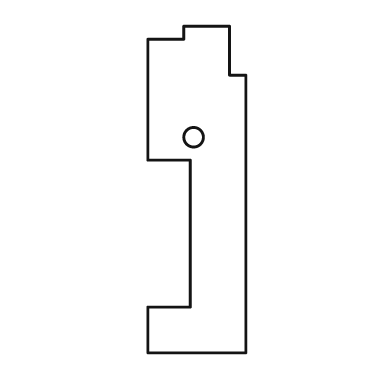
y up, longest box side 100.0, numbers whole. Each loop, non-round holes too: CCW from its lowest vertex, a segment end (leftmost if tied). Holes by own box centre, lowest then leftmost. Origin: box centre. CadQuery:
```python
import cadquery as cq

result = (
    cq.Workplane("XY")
    .moveTo(-15.0, -50.0)
    .lineTo(15.0, -50.0)
    .lineTo(15.0, 35.0)
    .lineTo(10.0, 35.0)
    .lineTo(10.0, 50.0)
    .lineTo(-4.0, 50.0)
    .lineTo(-4.0, 46.0)
    .lineTo(-15.0, 46.0)
    .lineTo(-15.0, 9.0)
    .lineTo(-2.0, 9.0)
    .lineTo(-2.0, -36.0)
    .lineTo(-15.0, -36.0)
    .close()
    .moveTo(-1.0, 16.0)
    .circle(3.0)
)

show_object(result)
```